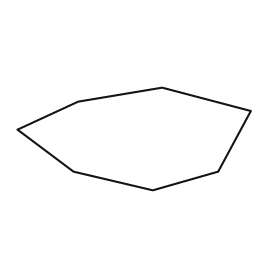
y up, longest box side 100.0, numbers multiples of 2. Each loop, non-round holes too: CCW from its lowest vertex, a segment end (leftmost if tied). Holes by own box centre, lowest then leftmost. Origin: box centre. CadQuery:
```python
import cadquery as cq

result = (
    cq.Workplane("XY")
    .moveTo(8.0, -22.0)
    .lineTo(36.0, -14.0)
    .lineTo(50.0, 12.0)
    .lineTo(12.0, 22.0)
    .lineTo(-24.0, 16.0)
    .lineTo(-50.0, 4.0)
    .lineTo(-26.0, -14.0)
    .close()
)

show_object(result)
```